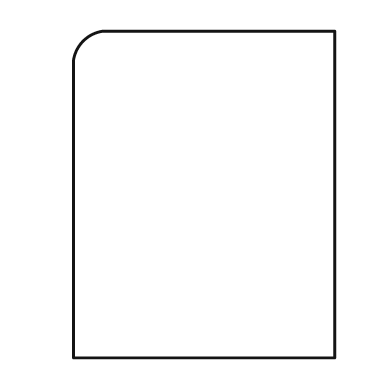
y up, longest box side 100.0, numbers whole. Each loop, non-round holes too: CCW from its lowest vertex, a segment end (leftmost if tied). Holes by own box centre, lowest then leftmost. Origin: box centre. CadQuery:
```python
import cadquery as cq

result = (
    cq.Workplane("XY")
    .moveTo(-40.0, -50.0)
    .lineTo(40.0, -50.0)
    .lineTo(40.0, 50.0)
    .lineTo(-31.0, 50.0)
    .threePointArc((-37.0, 47.0), (-40.0, 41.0))
    .close()
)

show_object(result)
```